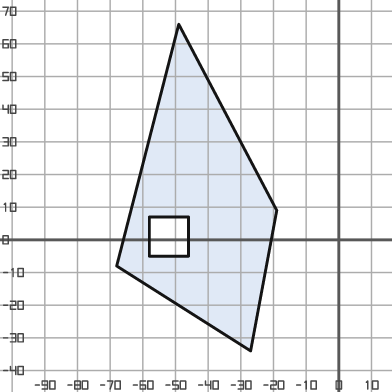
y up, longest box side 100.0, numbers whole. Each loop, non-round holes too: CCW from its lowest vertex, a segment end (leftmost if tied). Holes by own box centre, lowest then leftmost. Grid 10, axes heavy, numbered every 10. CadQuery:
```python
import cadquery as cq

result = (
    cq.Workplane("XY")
    .moveTo(-27.0, -34.0)
    .lineTo(-19.0, 9.0)
    .lineTo(-49.0, 66.0)
    .lineTo(-68.0, -8.0)
    .close()
    .moveTo(-58.0, -5.0)
    .lineTo(-46.0, -5.0)
    .lineTo(-46.0, 7.0)
    .lineTo(-58.0, 7.0)
    .close()
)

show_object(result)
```